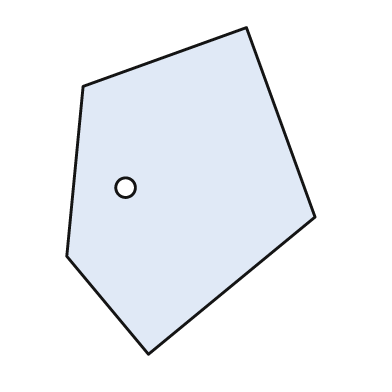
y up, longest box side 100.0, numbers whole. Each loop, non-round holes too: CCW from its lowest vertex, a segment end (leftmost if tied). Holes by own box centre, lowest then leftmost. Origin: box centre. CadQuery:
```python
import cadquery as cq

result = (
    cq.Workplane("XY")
    .moveTo(-13.0, -50.0)
    .lineTo(38.0, -8.0)
    .lineTo(17.0, 50.0)
    .lineTo(-33.0, 32.0)
    .lineTo(-38.0, -20.0)
    .close()
    .moveTo(-20.0, 1.0)
    .circle(3.0)
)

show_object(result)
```